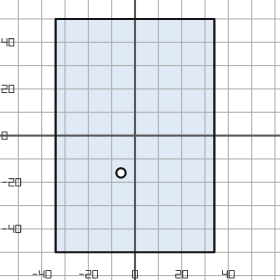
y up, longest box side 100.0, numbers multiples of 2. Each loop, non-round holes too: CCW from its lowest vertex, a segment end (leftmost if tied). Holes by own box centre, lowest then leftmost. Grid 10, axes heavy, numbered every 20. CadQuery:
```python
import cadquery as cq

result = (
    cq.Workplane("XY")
    .moveTo(-34.0, -50.0)
    .lineTo(34.0, -50.0)
    .lineTo(34.0, 50.0)
    .lineTo(-34.0, 50.0)
    .close()
    .moveTo(-6.0, -16.0)
    .circle(2.0)
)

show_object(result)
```